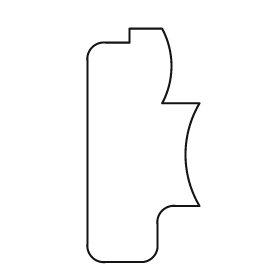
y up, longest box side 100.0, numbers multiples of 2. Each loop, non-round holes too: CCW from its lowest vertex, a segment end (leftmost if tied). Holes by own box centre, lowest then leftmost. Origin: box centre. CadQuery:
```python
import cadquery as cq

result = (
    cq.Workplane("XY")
    .moveTo(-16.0, -50.0)
    .lineTo(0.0, -50.0)
    .threePointArc((4.0, -48.0), (6.0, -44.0))
    .lineTo(6.0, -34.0)
    .threePointArc((8.0, -28.0), (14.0, -26.0))
    .lineTo(24.0, -26.0)
    .threePointArc((18.0, -4.0), (24.0, 18.0))
    .lineTo(8.0, 18.0)
    .threePointArc((12.0, 34.0), (8.0, 50.0))
    .lineTo(-6.0, 50.0)
    .lineTo(-6.0, 44.0)
    .lineTo(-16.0, 44.0)
    .threePointArc((-22.0, 42.0), (-24.0, 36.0))
    .lineTo(-24.0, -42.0)
    .threePointArc((-22.0, -48.0), (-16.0, -50.0))
    .close()
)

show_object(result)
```